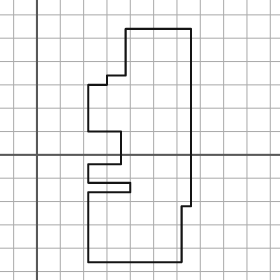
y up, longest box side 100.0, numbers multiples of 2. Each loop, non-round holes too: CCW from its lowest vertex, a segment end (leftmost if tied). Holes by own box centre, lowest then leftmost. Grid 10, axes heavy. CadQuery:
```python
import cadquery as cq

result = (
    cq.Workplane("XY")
    .moveTo(22.0, -46.0)
    .lineTo(62.0, -46.0)
    .lineTo(62.0, -22.0)
    .lineTo(66.0, -22.0)
    .lineTo(66.0, 54.0)
    .lineTo(38.0, 54.0)
    .lineTo(38.0, 34.0)
    .lineTo(30.0, 34.0)
    .lineTo(30.0, 30.0)
    .lineTo(22.0, 30.0)
    .lineTo(22.0, 10.0)
    .lineTo(36.0, 10.0)
    .lineTo(36.0, -4.0)
    .lineTo(22.0, -4.0)
    .lineTo(22.0, -12.0)
    .lineTo(40.0, -12.0)
    .lineTo(40.0, -16.0)
    .lineTo(22.0, -16.0)
    .close()
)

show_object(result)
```